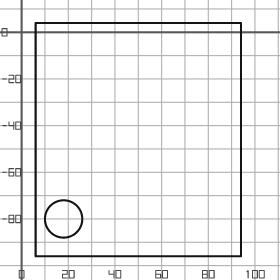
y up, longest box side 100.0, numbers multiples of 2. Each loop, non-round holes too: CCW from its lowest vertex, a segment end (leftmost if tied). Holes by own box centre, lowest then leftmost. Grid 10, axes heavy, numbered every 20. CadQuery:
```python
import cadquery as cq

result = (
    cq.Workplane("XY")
    .moveTo(6.0, -96.0)
    .lineTo(94.0, -96.0)
    .lineTo(94.0, 4.0)
    .lineTo(6.0, 4.0)
    .close()
    .moveTo(18.0, -80.0)
    .circle(8.0)
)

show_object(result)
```